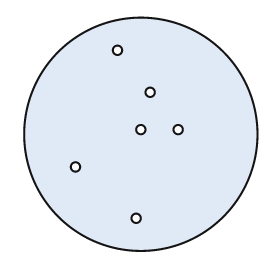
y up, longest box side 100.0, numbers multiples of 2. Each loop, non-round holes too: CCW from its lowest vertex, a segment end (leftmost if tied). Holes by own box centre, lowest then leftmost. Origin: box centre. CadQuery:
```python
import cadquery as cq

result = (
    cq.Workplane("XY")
    .moveTo(0.0, 0.0)
    .circle(50.0)
    .moveTo(-2.0, -36.0)
    .circle(2.0)
    .moveTo(-28.0, -14.0)
    .circle(2.0)
    .moveTo(0.0, 2.0)
    .circle(2.0)
    .moveTo(16.0, 2.0)
    .circle(2.0)
    .moveTo(4.0, 18.0)
    .circle(2.0)
    .moveTo(-10.0, 36.0)
    .circle(2.0)
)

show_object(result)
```